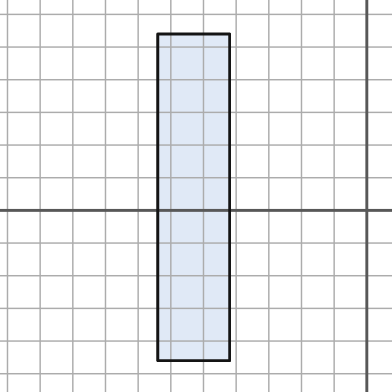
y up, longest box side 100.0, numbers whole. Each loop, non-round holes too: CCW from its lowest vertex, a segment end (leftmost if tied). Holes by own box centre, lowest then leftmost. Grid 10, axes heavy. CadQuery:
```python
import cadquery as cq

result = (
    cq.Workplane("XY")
    .moveTo(-64.0, -46.0)
    .lineTo(-42.0, -46.0)
    .lineTo(-42.0, 54.0)
    .lineTo(-64.0, 54.0)
    .close()
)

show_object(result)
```